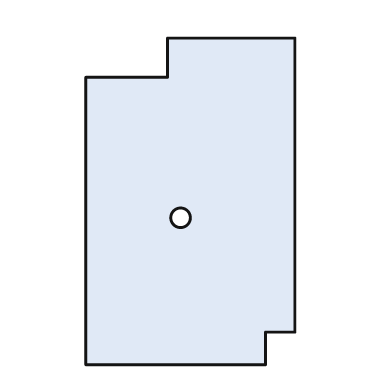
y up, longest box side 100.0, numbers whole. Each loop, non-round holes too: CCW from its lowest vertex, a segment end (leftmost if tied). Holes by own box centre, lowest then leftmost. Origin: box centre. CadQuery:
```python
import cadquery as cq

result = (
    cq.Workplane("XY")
    .moveTo(-32.0, -50.0)
    .lineTo(23.0, -50.0)
    .lineTo(23.0, -40.0)
    .lineTo(32.0, -40.0)
    .lineTo(32.0, 50.0)
    .lineTo(-7.0, 50.0)
    .lineTo(-7.0, 38.0)
    .lineTo(-32.0, 38.0)
    .close()
    .moveTo(-3.0, -5.0)
    .circle(3.0)
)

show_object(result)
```